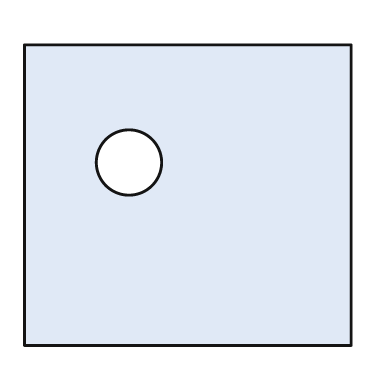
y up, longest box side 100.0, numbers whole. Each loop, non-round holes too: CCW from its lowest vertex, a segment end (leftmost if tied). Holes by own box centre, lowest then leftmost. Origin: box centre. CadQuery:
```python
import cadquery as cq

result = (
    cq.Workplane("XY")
    .moveTo(-50.0, -46.0)
    .lineTo(50.0, -46.0)
    .lineTo(50.0, 46.0)
    .lineTo(-50.0, 46.0)
    .close()
    .moveTo(-18.0, 10.0)
    .circle(10.0)
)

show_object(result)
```